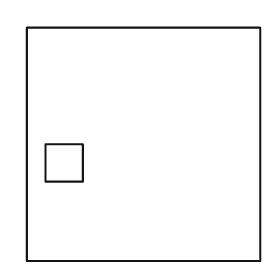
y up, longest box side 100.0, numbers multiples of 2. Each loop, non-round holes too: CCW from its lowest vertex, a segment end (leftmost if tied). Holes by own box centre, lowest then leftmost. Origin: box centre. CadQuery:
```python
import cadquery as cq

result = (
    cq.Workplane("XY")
    .moveTo(-50.0, -50.0)
    .lineTo(50.0, -50.0)
    .lineTo(50.0, 50.0)
    .lineTo(-50.0, 50.0)
    .close()
    .moveTo(-42.0, -16.0)
    .lineTo(-26.0, -16.0)
    .lineTo(-26.0, 0.0)
    .lineTo(-42.0, 0.0)
    .close()
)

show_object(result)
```